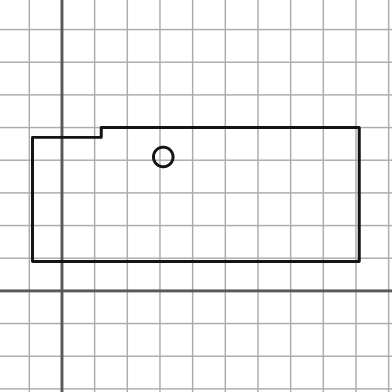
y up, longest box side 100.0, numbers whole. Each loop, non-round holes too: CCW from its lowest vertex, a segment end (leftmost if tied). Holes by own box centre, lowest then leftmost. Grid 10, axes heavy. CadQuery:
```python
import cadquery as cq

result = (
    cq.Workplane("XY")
    .moveTo(-9.0, 9.0)
    .lineTo(91.0, 9.0)
    .lineTo(91.0, 50.0)
    .lineTo(12.0, 50.0)
    .lineTo(12.0, 47.0)
    .lineTo(-9.0, 47.0)
    .close()
    .moveTo(31.0, 41.0)
    .circle(3.0)
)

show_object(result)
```